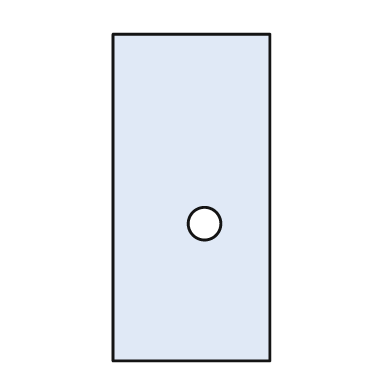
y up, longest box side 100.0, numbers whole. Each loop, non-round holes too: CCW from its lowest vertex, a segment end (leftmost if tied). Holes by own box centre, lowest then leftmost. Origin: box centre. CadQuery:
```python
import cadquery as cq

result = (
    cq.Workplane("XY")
    .moveTo(-24.0, -50.0)
    .lineTo(24.0, -50.0)
    .lineTo(24.0, 50.0)
    .lineTo(-24.0, 50.0)
    .close()
    .moveTo(4.0, -8.0)
    .circle(5.0)
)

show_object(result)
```